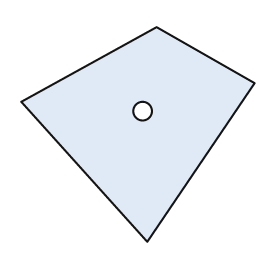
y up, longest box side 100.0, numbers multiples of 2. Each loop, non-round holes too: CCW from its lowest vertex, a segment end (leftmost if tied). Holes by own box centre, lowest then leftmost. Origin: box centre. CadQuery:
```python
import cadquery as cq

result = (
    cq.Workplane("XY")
    .moveTo(4.0, -46.0)
    .lineTo(50.0, 22.0)
    .lineTo(8.0, 46.0)
    .lineTo(-50.0, 14.0)
    .close()
    .moveTo(2.0, 10.0)
    .circle(4.0)
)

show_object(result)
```